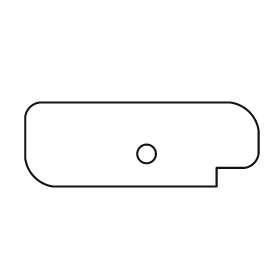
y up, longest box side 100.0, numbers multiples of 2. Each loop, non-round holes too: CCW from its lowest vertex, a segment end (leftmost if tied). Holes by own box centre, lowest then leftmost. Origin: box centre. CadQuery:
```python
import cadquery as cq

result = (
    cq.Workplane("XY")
    .moveTo(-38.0, -18.0)
    .lineTo(32.0, -18.0)
    .lineTo(32.0, -10.0)
    .lineTo(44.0, -10.0)
    .threePointArc((48.0, -8.0), (50.0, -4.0))
    .lineTo(50.0, 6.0)
    .threePointArc((46.0, 14.0), (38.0, 18.0))
    .lineTo(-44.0, 18.0)
    .threePointArc((-48.0, 16.0), (-50.0, 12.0))
    .lineTo(-50.0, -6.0)
    .threePointArc((-46.0, -14.0), (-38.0, -18.0))
    .close()
    .moveTo(2.0, -4.0)
    .circle(4.0)
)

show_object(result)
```